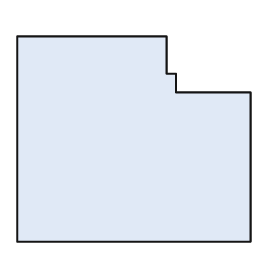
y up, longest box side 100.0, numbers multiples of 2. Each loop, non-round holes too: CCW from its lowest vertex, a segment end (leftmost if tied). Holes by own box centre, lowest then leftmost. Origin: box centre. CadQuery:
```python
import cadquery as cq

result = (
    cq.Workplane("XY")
    .moveTo(-50.0, -44.0)
    .lineTo(50.0, -44.0)
    .lineTo(50.0, 20.0)
    .lineTo(18.0, 20.0)
    .lineTo(18.0, 28.0)
    .lineTo(14.0, 28.0)
    .lineTo(14.0, 44.0)
    .lineTo(-50.0, 44.0)
    .close()
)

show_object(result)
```